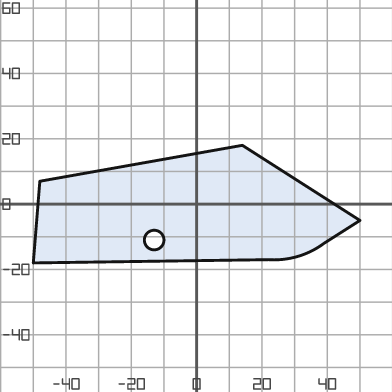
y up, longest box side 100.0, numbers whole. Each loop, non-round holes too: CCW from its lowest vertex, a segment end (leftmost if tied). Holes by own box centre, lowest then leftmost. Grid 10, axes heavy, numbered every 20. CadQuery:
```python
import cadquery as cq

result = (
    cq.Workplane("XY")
    .moveTo(-50.0, -18.0)
    .lineTo(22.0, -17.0)
    .threePointArc((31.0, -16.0), (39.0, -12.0))
    .lineTo(50.0, -5.0)
    .lineTo(14.0, 18.0)
    .lineTo(-48.0, 7.0)
    .close()
    .moveTo(-13.0, -11.0)
    .circle(3.0)
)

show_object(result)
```